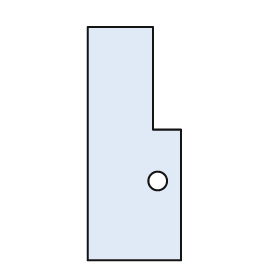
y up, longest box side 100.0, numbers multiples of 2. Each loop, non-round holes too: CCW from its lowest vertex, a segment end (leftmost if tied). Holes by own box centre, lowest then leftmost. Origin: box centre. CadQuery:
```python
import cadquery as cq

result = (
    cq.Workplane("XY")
    .moveTo(-20.0, -50.0)
    .lineTo(20.0, -50.0)
    .lineTo(20.0, 6.0)
    .lineTo(8.0, 6.0)
    .lineTo(8.0, 50.0)
    .lineTo(-20.0, 50.0)
    .close()
    .moveTo(10.0, -16.0)
    .circle(4.0)
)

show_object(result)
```